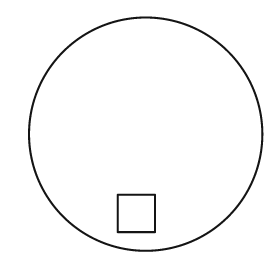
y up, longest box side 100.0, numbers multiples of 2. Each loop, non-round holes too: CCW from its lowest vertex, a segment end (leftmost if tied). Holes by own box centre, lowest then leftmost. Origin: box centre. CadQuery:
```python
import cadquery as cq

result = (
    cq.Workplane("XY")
    .moveTo(0.0, 0.0)
    .circle(50.0)
    .moveTo(-12.0, -42.0)
    .lineTo(4.0, -42.0)
    .lineTo(4.0, -26.0)
    .lineTo(-12.0, -26.0)
    .close()
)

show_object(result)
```